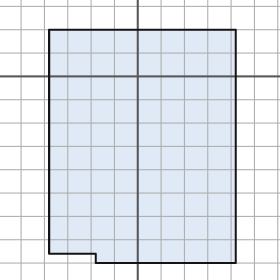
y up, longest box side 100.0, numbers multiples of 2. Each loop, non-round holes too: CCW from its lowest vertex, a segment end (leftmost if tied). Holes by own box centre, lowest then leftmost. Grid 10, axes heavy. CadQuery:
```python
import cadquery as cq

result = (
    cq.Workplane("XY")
    .moveTo(-18.0, -80.0)
    .lineTo(42.0, -80.0)
    .lineTo(42.0, 20.0)
    .lineTo(-38.0, 20.0)
    .lineTo(-38.0, -76.0)
    .lineTo(-18.0, -76.0)
    .close()
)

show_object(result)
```